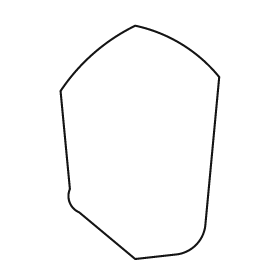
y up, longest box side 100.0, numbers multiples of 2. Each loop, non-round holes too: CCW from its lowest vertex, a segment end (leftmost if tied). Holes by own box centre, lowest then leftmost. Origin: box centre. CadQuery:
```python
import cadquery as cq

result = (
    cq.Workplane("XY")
    .moveTo(-2.0, -50.0)
    .lineTo(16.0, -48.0)
    .threePointArc((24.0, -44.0), (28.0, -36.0))
    .lineTo(34.0, 28.0)
    .threePointArc((18.0, 42.0), (-2.0, 50.0))
    .threePointArc((-20.0, 38.0), (-34.0, 22.0))
    .lineTo(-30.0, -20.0)
    .threePointArc((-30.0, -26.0), (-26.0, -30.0))
    .close()
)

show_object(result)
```